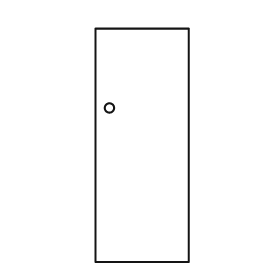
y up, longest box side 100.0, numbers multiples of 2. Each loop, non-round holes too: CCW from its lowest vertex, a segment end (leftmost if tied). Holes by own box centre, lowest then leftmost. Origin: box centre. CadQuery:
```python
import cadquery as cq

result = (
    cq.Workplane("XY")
    .moveTo(-20.0, -50.0)
    .lineTo(20.0, -50.0)
    .lineTo(20.0, 50.0)
    .lineTo(-20.0, 50.0)
    .close()
    .moveTo(-14.0, 16.0)
    .circle(2.0)
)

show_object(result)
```